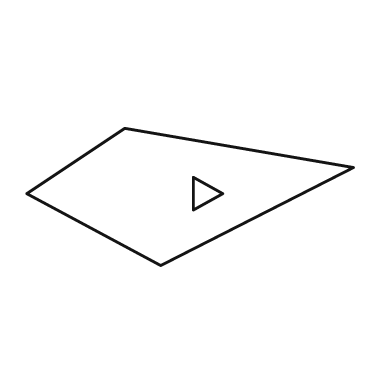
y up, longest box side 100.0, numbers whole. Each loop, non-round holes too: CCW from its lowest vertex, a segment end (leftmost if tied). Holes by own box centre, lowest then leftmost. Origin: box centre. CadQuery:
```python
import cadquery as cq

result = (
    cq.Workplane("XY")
    .moveTo(-9.0, -21.0)
    .lineTo(50.0, 9.0)
    .lineTo(-20.0, 21.0)
    .lineTo(-50.0, 1.0)
    .close()
    .moveTo(1.0, -4.0)
    .lineTo(10.0, 1.0)
    .lineTo(1.0, 6.0)
    .close()
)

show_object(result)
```